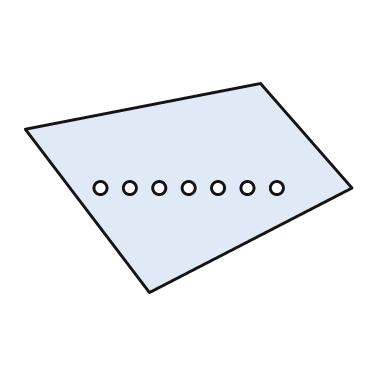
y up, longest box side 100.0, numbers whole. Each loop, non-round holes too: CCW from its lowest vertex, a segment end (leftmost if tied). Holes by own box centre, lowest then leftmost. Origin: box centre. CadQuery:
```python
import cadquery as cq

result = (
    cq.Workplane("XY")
    .moveTo(-12.0, -32.0)
    .lineTo(50.0, 0.0)
    .lineTo(22.0, 32.0)
    .lineTo(-50.0, 18.0)
    .close()
    .moveTo(-27.0, 0.0)
    .circle(2.0)
    .moveTo(-18.0, 0.0)
    .circle(2.0)
    .moveTo(-9.0, 0.0)
    .circle(2.0)
    .moveTo(0.0, 0.0)
    .circle(2.0)
    .moveTo(9.0, 0.0)
    .circle(2.0)
    .moveTo(18.0, 0.0)
    .circle(2.0)
    .moveTo(27.0, 0.0)
    .circle(2.0)
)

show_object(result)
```